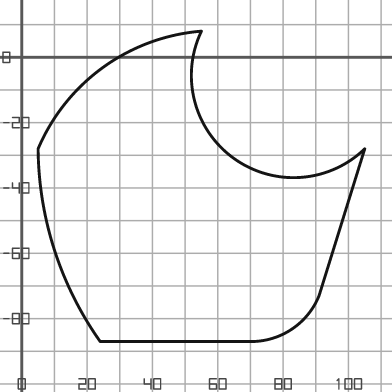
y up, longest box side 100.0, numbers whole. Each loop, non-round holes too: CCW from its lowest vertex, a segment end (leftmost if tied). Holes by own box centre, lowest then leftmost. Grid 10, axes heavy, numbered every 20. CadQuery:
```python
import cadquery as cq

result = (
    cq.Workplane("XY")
    .moveTo(24.0, -87.0)
    .lineTo(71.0, -87.0)
    .threePointArc((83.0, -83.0), (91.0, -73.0))
    .lineTo(105.0, -28.0)
    .threePointArc((65.0, -31.0), (55.0, 8.0))
    .threePointArc((25.0, -3.0), (5.0, -28.0))
    .threePointArc((10.0, -59.0), (24.0, -87.0))
    .close()
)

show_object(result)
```